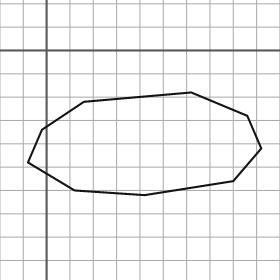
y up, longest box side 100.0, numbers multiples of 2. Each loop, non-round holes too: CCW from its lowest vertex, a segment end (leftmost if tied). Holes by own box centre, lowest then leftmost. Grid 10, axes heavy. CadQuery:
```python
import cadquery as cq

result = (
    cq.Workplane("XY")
    .moveTo(42.0, -62.0)
    .lineTo(80.0, -56.0)
    .lineTo(92.0, -42.0)
    .lineTo(86.0, -28.0)
    .lineTo(62.0, -18.0)
    .lineTo(16.0, -22.0)
    .lineTo(-2.0, -34.0)
    .lineTo(-8.0, -48.0)
    .lineTo(12.0, -60.0)
    .close()
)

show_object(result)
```